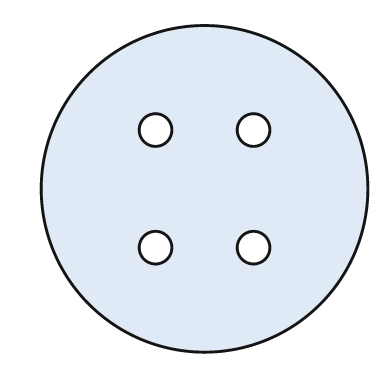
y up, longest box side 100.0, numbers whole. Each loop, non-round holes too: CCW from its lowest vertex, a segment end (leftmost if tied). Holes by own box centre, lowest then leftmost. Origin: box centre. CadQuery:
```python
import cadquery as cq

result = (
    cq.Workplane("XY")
    .moveTo(0.0, 0.0)
    .circle(50.0)
    .moveTo(-15.0, -18.0)
    .circle(5.0)
    .moveTo(15.0, -18.0)
    .circle(5.0)
    .moveTo(-15.0, 18.0)
    .circle(5.0)
    .moveTo(15.0, 18.0)
    .circle(5.0)
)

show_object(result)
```